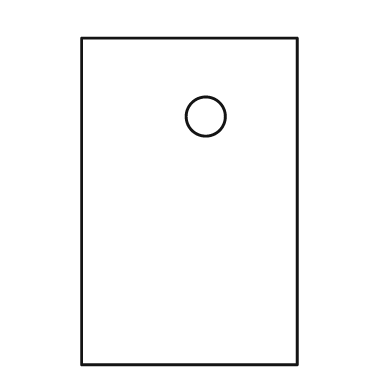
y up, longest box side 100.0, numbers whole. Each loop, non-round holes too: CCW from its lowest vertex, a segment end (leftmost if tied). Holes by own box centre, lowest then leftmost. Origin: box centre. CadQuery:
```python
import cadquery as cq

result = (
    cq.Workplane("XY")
    .moveTo(-33.0, -50.0)
    .lineTo(33.0, -50.0)
    .lineTo(33.0, 50.0)
    .lineTo(-33.0, 50.0)
    .close()
    .moveTo(5.0, 26.0)
    .circle(6.0)
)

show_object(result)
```